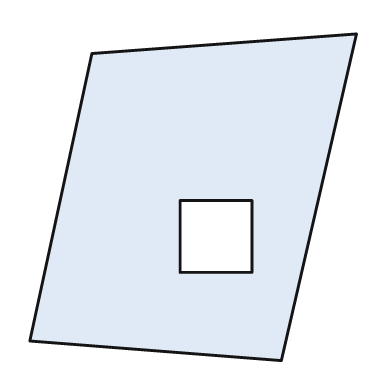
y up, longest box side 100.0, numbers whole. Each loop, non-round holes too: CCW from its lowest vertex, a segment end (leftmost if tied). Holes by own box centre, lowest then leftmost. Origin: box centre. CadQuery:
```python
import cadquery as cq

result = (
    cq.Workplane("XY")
    .moveTo(27.0, -50.0)
    .lineTo(50.0, 50.0)
    .lineTo(-31.0, 44.0)
    .lineTo(-50.0, -44.0)
    .close()
    .moveTo(-4.0, -23.0)
    .lineTo(18.0, -23.0)
    .lineTo(18.0, -1.0)
    .lineTo(-4.0, -1.0)
    .close()
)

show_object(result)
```